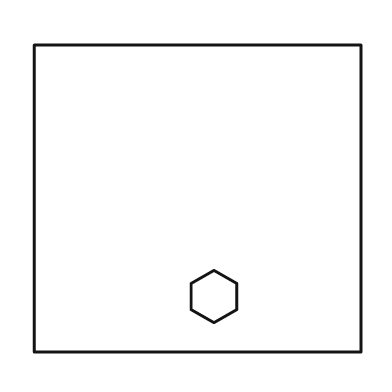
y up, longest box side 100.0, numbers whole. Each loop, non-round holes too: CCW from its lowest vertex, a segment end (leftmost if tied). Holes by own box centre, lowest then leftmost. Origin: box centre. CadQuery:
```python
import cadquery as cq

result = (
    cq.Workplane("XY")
    .moveTo(-50.0, -47.0)
    .lineTo(50.0, -47.0)
    .lineTo(50.0, 47.0)
    .lineTo(-50.0, 47.0)
    .close()
    .moveTo(5.0, -38.0)
    .lineTo(12.0, -34.0)
    .lineTo(12.0, -26.0)
    .lineTo(5.0, -22.0)
    .lineTo(-2.0, -26.0)
    .lineTo(-2.0, -34.0)
    .close()
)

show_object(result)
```